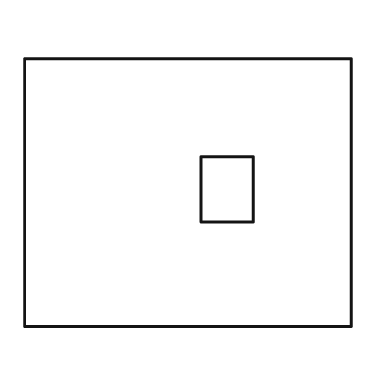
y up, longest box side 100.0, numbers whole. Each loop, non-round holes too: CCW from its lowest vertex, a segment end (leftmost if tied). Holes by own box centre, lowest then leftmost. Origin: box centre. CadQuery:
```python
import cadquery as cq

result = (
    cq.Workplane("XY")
    .moveTo(-50.0, -41.0)
    .lineTo(50.0, -41.0)
    .lineTo(50.0, 41.0)
    .lineTo(-50.0, 41.0)
    .close()
    .moveTo(4.0, -9.0)
    .lineTo(20.0, -9.0)
    .lineTo(20.0, 11.0)
    .lineTo(4.0, 11.0)
    .close()
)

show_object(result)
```